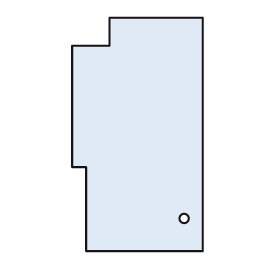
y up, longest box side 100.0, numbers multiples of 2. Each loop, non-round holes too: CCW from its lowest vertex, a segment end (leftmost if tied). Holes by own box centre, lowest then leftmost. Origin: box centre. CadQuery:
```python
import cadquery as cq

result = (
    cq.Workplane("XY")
    .moveTo(-22.0, -50.0)
    .lineTo(28.0, -50.0)
    .lineTo(28.0, 50.0)
    .lineTo(-12.0, 50.0)
    .lineTo(-12.0, 38.0)
    .lineTo(-28.0, 38.0)
    .lineTo(-28.0, -14.0)
    .lineTo(-22.0, -14.0)
    .close()
    .moveTo(20.0, -36.0)
    .circle(2.0)
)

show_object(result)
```